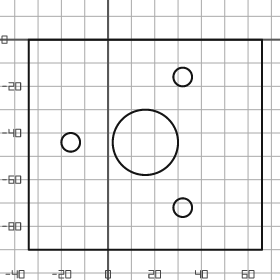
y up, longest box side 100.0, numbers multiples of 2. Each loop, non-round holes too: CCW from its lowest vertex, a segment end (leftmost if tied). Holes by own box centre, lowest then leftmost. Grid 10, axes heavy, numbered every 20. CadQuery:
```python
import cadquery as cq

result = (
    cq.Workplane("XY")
    .moveTo(-34.0, -90.0)
    .lineTo(66.0, -90.0)
    .lineTo(66.0, 0.0)
    .lineTo(-34.0, 0.0)
    .close()
    .moveTo(32.0, -72.0)
    .circle(4.0)
    .moveTo(-16.0, -44.0)
    .circle(4.0)
    .moveTo(16.0, -44.0)
    .circle(14.0)
    .moveTo(32.0, -16.0)
    .circle(4.0)
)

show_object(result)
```